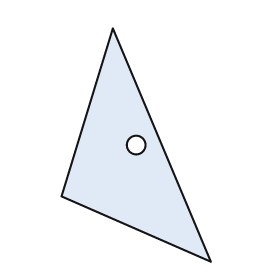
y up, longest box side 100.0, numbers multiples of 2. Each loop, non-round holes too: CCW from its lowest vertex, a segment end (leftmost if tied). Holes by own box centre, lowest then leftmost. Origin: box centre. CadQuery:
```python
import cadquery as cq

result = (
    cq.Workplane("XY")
    .moveTo(32.0, -50.0)
    .lineTo(-10.0, 50.0)
    .lineTo(-32.0, -22.0)
    .close()
    .moveTo(0.0, 0.0)
    .circle(4.0)
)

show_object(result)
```